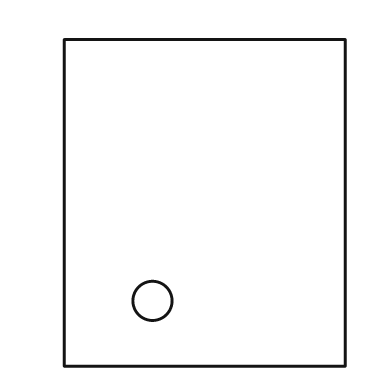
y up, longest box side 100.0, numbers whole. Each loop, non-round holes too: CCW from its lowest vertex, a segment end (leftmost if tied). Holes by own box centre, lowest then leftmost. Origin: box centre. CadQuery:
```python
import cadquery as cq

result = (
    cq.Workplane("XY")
    .moveTo(-43.0, -50.0)
    .lineTo(43.0, -50.0)
    .lineTo(43.0, 50.0)
    .lineTo(-43.0, 50.0)
    .close()
    .moveTo(-16.0, -30.0)
    .circle(6.0)
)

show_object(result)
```